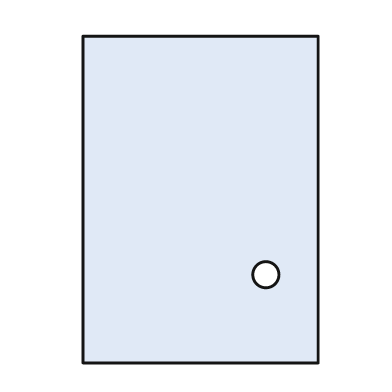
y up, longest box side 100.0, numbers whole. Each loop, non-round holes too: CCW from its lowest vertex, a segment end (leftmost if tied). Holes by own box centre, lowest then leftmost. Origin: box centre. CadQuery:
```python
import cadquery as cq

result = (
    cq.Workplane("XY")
    .moveTo(-36.0, -50.0)
    .lineTo(36.0, -50.0)
    .lineTo(36.0, 50.0)
    .lineTo(-36.0, 50.0)
    .close()
    .moveTo(20.0, -23.0)
    .circle(4.0)
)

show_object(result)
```